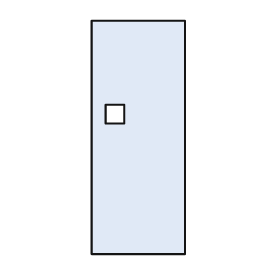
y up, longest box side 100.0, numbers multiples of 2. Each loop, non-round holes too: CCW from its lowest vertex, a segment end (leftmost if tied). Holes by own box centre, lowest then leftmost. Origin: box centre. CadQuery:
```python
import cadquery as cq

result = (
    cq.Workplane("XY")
    .moveTo(-20.0, -50.0)
    .lineTo(20.0, -50.0)
    .lineTo(20.0, 50.0)
    .lineTo(-20.0, 50.0)
    .close()
    .moveTo(-14.0, 6.0)
    .lineTo(-6.0, 6.0)
    .lineTo(-6.0, 14.0)
    .lineTo(-14.0, 14.0)
    .close()
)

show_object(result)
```